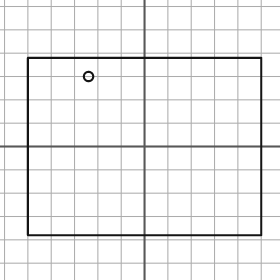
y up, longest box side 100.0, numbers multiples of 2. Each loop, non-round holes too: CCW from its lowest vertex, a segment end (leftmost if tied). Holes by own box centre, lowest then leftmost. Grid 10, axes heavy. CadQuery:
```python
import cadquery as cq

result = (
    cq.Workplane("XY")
    .moveTo(-50.0, -38.0)
    .lineTo(50.0, -38.0)
    .lineTo(50.0, 38.0)
    .lineTo(-50.0, 38.0)
    .close()
    .moveTo(-24.0, 30.0)
    .circle(2.0)
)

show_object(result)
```